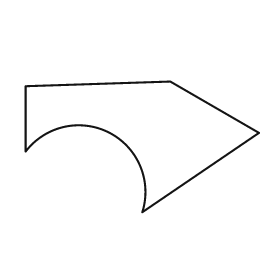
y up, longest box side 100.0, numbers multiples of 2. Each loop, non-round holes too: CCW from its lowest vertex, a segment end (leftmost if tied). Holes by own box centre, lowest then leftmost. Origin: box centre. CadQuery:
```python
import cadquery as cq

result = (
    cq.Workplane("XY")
    .moveTo(0.0, -28.0)
    .lineTo(50.0, 6.0)
    .lineTo(12.0, 28.0)
    .lineTo(-50.0, 26.0)
    .lineTo(-50.0, -2.0)
    .threePointArc((-14.0, 6.0), (0.0, -28.0))
    .close()
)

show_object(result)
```